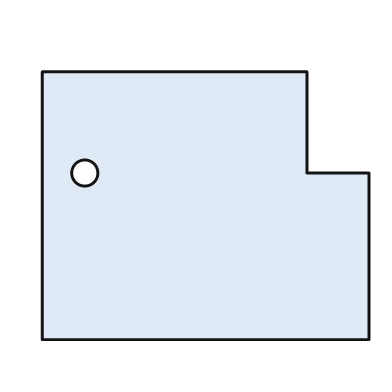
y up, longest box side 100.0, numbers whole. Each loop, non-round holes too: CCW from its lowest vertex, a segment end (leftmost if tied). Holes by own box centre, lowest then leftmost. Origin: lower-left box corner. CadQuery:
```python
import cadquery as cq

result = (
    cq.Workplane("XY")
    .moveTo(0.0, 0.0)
    .lineTo(100.0, 0.0)
    .lineTo(100.0, 51.0)
    .lineTo(81.0, 51.0)
    .lineTo(81.0, 82.0)
    .lineTo(0.0, 82.0)
    .close()
    .moveTo(13.0, 51.0)
    .circle(4.0)
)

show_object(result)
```